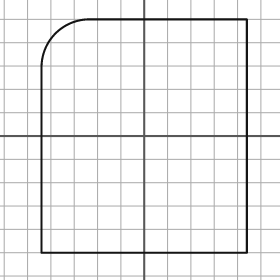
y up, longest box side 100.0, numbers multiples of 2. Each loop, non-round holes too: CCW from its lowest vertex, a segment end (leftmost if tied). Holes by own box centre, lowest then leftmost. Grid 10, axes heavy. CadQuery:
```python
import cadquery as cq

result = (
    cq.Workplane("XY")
    .moveTo(-44.0, -50.0)
    .lineTo(44.0, -50.0)
    .lineTo(44.0, 50.0)
    .lineTo(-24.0, 50.0)
    .threePointArc((-38.0, 44.0), (-44.0, 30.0))
    .close()
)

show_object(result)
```